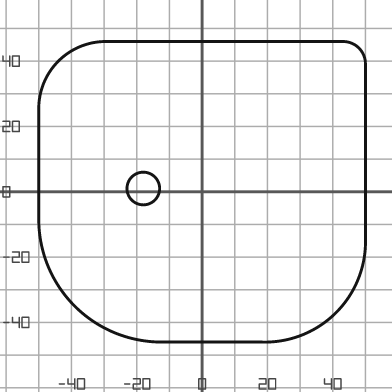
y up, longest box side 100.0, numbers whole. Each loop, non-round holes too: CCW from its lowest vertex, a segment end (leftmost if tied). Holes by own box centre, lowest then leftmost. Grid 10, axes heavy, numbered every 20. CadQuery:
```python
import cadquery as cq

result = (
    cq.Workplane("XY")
    .moveTo(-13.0, -46.0)
    .lineTo(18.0, -46.0)
    .threePointArc((41.0, -37.0), (50.0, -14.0))
    .lineTo(50.0, 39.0)
    .threePointArc((48.0, 44.0), (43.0, 46.0))
    .lineTo(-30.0, 46.0)
    .threePointArc((-44.0, 40.0), (-50.0, 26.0))
    .lineTo(-50.0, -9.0)
    .threePointArc((-39.0, -35.0), (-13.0, -46.0))
    .close()
    .moveTo(-18.0, 1.0)
    .circle(5.0)
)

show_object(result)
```